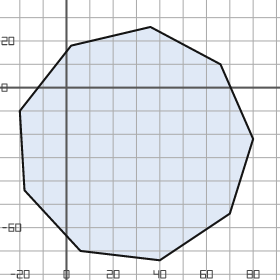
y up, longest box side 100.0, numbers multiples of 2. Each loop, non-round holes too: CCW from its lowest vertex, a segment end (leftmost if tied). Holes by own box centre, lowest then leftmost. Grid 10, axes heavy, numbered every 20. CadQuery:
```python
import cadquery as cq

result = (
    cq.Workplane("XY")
    .moveTo(40.0, -74.0)
    .lineTo(70.0, -54.0)
    .lineTo(80.0, -22.0)
    .lineTo(66.0, 10.0)
    .lineTo(36.0, 26.0)
    .lineTo(2.0, 18.0)
    .lineTo(-20.0, -10.0)
    .lineTo(-18.0, -44.0)
    .lineTo(6.0, -70.0)
    .close()
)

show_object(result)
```